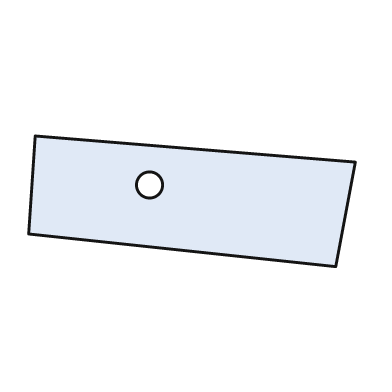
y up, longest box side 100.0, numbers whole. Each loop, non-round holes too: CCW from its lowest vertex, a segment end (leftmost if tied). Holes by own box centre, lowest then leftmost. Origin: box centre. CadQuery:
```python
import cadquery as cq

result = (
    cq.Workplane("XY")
    .moveTo(44.0, -20.0)
    .lineTo(50.0, 12.0)
    .lineTo(-48.0, 20.0)
    .lineTo(-50.0, -10.0)
    .close()
    .moveTo(-13.0, 5.0)
    .circle(4.0)
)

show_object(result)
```